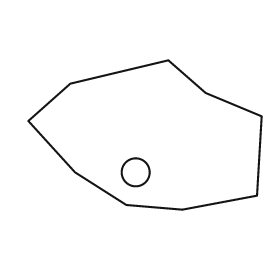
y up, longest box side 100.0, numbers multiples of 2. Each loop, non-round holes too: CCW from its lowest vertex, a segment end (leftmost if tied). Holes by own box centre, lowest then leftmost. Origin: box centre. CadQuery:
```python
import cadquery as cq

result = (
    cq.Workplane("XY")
    .moveTo(16.0, -32.0)
    .lineTo(48.0, -26.0)
    .lineTo(50.0, 8.0)
    .lineTo(26.0, 18.0)
    .lineTo(10.0, 32.0)
    .lineTo(-32.0, 22.0)
    .lineTo(-50.0, 6.0)
    .lineTo(-30.0, -16.0)
    .lineTo(-8.0, -30.0)
    .close()
    .moveTo(-4.0, -16.0)
    .circle(6.0)
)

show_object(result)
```